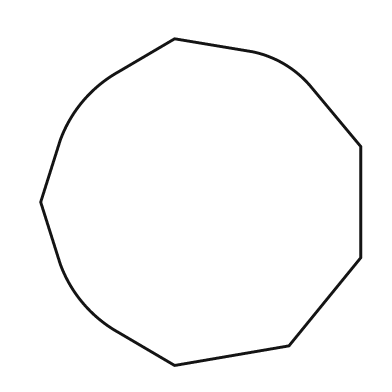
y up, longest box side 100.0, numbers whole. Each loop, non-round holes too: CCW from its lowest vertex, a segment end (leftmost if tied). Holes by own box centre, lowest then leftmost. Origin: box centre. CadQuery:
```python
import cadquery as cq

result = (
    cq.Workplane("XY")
    .moveTo(-8.0, -50.0)
    .lineTo(27.0, -44.0)
    .lineTo(49.0, -17.0)
    .lineTo(49.0, 17.0)
    .lineTo(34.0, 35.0)
    .threePointArc((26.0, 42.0), (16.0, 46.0))
    .lineTo(-8.0, 50.0)
    .lineTo(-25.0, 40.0)
    .threePointArc((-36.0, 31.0), (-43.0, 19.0))
    .lineTo(-49.0, 0.0)
    .lineTo(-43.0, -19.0)
    .threePointArc((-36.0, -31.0), (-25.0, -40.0))
    .close()
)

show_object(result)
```